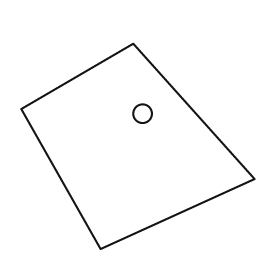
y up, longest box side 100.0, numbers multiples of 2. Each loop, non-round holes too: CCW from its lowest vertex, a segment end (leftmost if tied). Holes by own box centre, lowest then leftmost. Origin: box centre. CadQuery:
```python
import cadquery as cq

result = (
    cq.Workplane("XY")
    .moveTo(-16.0, -44.0)
    .lineTo(50.0, -14.0)
    .lineTo(-2.0, 44.0)
    .lineTo(-50.0, 16.0)
    .close()
    .moveTo(2.0, 14.0)
    .circle(4.0)
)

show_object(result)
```